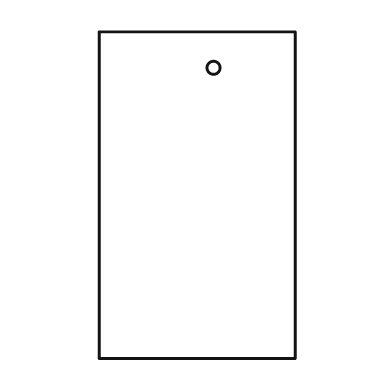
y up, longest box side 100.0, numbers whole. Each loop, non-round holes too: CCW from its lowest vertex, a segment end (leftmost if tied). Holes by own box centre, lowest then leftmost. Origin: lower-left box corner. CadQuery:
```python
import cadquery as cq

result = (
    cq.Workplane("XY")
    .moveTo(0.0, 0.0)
    .lineTo(60.0, 0.0)
    .lineTo(60.0, 100.0)
    .lineTo(0.0, 100.0)
    .close()
    .moveTo(35.0, 89.0)
    .circle(2.0)
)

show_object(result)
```